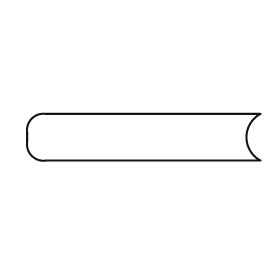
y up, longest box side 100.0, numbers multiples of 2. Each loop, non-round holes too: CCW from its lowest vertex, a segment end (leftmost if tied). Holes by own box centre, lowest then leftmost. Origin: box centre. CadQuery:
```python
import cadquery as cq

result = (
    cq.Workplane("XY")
    .moveTo(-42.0, -10.0)
    .lineTo(50.0, -10.0)
    .threePointArc((44.0, 0.0), (50.0, 10.0))
    .lineTo(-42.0, 10.0)
    .threePointArc((-48.0, 8.0), (-50.0, 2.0))
    .lineTo(-50.0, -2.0)
    .threePointArc((-48.0, -8.0), (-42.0, -10.0))
    .close()
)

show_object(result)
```